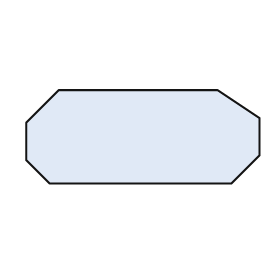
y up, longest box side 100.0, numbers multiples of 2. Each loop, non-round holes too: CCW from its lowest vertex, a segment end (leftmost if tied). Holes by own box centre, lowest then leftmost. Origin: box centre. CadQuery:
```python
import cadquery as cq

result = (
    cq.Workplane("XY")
    .moveTo(-40.0, -20.0)
    .lineTo(38.0, -20.0)
    .lineTo(50.0, -8.0)
    .lineTo(50.0, 8.0)
    .lineTo(32.0, 20.0)
    .lineTo(-36.0, 20.0)
    .lineTo(-50.0, 6.0)
    .lineTo(-50.0, -10.0)
    .close()
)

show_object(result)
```